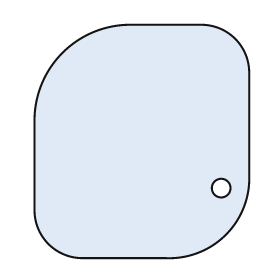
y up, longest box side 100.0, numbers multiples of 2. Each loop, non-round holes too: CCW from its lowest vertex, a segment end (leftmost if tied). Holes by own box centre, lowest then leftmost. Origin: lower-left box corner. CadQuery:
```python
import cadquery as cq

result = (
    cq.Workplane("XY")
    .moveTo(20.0, 0.0)
    .lineTo(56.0, 0.0)
    .threePointArc((82.0, 10.0), (92.0, 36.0))
    .lineTo(92.0, 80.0)
    .threePointArc((86.0, 94.0), (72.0, 100.0))
    .lineTo(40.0, 100.0)
    .threePointArc((12.0, 88.0), (0.0, 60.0))
    .lineTo(0.0, 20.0)
    .threePointArc((6.0, 6.0), (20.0, 0.0))
    .close()
    .moveTo(80.0, 30.0)
    .circle(4.0)
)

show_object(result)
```